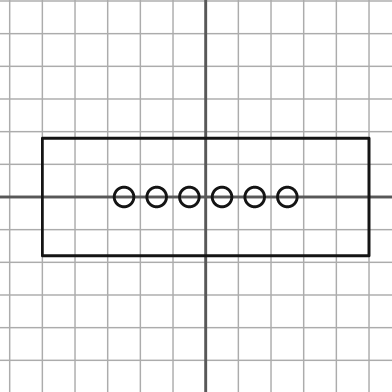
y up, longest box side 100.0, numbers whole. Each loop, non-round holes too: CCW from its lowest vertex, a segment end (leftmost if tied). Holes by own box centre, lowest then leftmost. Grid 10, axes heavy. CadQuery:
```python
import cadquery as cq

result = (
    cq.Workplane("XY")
    .moveTo(-50.0, -18.0)
    .lineTo(50.0, -18.0)
    .lineTo(50.0, 18.0)
    .lineTo(-50.0, 18.0)
    .close()
    .moveTo(-25.0, 0.0)
    .circle(3.0)
    .moveTo(-15.0, 0.0)
    .circle(3.0)
    .moveTo(-5.0, 0.0)
    .circle(3.0)
    .moveTo(5.0, 0.0)
    .circle(3.0)
    .moveTo(15.0, 0.0)
    .circle(3.0)
    .moveTo(25.0, 0.0)
    .circle(3.0)
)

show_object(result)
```